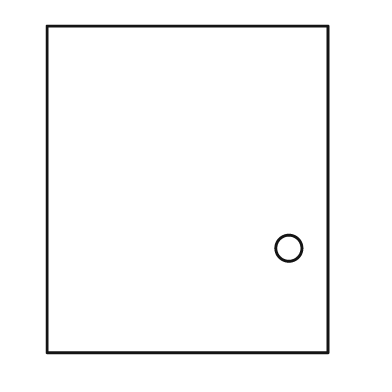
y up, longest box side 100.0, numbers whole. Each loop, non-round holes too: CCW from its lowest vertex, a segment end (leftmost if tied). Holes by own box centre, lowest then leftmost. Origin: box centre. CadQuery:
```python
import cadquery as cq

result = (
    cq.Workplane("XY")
    .moveTo(-43.0, -50.0)
    .lineTo(43.0, -50.0)
    .lineTo(43.0, 50.0)
    .lineTo(-43.0, 50.0)
    .close()
    .moveTo(31.0, -18.0)
    .circle(4.0)
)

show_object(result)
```